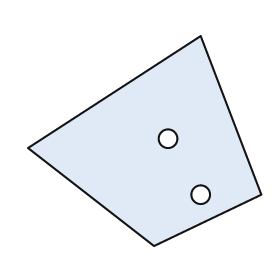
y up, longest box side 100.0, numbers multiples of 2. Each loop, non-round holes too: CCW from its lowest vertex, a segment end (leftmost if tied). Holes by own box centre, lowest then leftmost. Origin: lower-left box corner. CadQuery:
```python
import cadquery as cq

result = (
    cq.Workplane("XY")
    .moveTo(54.0, 0.0)
    .lineTo(100.0, 22.0)
    .lineTo(74.0, 90.0)
    .lineTo(0.0, 42.0)
    .close()
    .moveTo(74.0, 22.0)
    .circle(4.0)
    .moveTo(60.0, 46.0)
    .circle(4.0)
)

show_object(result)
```